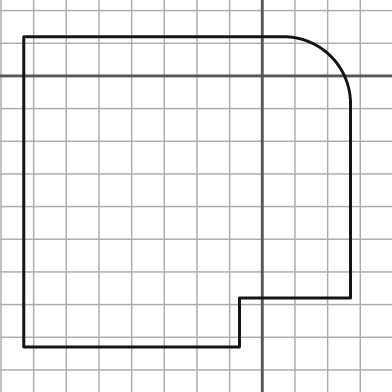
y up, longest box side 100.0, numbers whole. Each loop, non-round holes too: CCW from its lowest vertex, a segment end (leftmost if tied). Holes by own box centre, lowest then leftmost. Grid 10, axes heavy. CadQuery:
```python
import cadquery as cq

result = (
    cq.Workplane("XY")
    .moveTo(-73.0, -83.0)
    .lineTo(-7.0, -83.0)
    .lineTo(-7.0, -68.0)
    .lineTo(27.0, -68.0)
    .lineTo(27.0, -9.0)
    .threePointArc((21.0, 6.0), (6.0, 12.0))
    .lineTo(-73.0, 12.0)
    .close()
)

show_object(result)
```